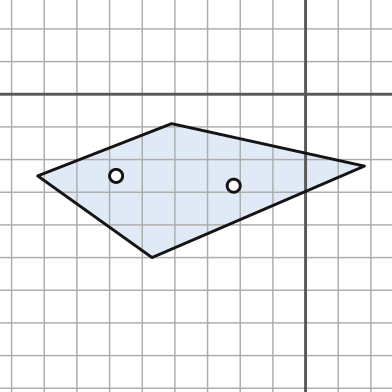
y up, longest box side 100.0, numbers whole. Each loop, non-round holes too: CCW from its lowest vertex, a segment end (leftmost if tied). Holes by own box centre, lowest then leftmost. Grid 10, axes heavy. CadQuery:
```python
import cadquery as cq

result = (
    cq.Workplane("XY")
    .moveTo(-47.0, -50.0)
    .lineTo(18.0, -22.0)
    .lineTo(-41.0, -9.0)
    .lineTo(-82.0, -25.0)
    .close()
    .moveTo(-22.0, -28.0)
    .circle(2.0)
    .moveTo(-58.0, -25.0)
    .circle(2.0)
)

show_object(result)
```